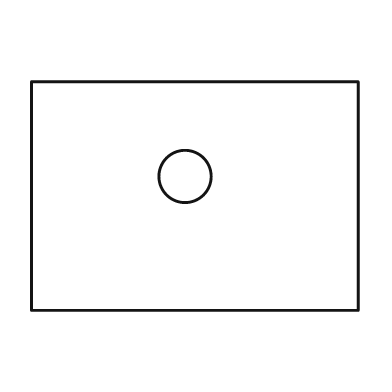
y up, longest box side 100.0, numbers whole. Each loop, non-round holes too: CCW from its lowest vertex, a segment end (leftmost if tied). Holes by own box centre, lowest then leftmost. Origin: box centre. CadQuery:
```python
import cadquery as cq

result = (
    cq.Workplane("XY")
    .moveTo(-50.0, -35.0)
    .lineTo(50.0, -35.0)
    .lineTo(50.0, 35.0)
    .lineTo(-50.0, 35.0)
    .close()
    .moveTo(-3.0, 6.0)
    .circle(8.0)
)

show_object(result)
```